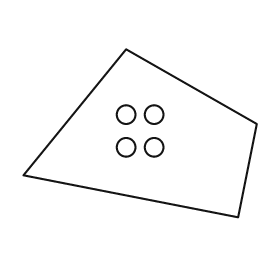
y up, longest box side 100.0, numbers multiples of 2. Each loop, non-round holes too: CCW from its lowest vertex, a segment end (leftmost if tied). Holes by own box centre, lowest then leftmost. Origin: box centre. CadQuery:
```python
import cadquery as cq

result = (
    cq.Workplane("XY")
    .moveTo(42.0, -36.0)
    .lineTo(50.0, 4.0)
    .lineTo(-6.0, 36.0)
    .lineTo(-50.0, -18.0)
    .close()
    .moveTo(-6.0, -6.0)
    .circle(4.0)
    .moveTo(6.0, -6.0)
    .circle(4.0)
    .moveTo(-6.0, 8.0)
    .circle(4.0)
    .moveTo(6.0, 8.0)
    .circle(4.0)
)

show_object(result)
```